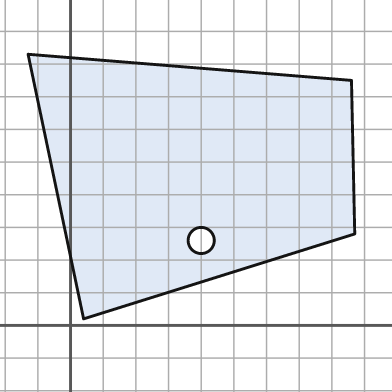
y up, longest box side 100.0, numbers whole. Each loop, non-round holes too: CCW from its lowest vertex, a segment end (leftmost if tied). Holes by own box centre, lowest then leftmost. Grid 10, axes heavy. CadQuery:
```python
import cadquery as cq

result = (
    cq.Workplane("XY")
    .moveTo(4.0, 2.0)
    .lineTo(87.0, 28.0)
    .lineTo(86.0, 75.0)
    .lineTo(-13.0, 83.0)
    .close()
    .moveTo(40.0, 26.0)
    .circle(4.0)
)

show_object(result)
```